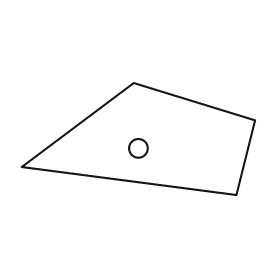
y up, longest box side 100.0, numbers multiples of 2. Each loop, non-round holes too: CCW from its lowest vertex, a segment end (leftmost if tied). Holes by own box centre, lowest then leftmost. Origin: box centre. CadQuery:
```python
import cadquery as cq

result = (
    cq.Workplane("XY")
    .moveTo(42.0, -24.0)
    .lineTo(50.0, 8.0)
    .lineTo(-2.0, 24.0)
    .lineTo(-50.0, -12.0)
    .close()
    .moveTo(0.0, -4.0)
    .circle(4.0)
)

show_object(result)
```